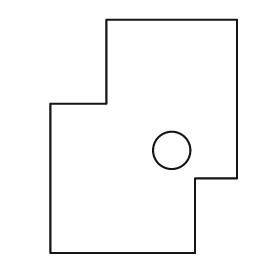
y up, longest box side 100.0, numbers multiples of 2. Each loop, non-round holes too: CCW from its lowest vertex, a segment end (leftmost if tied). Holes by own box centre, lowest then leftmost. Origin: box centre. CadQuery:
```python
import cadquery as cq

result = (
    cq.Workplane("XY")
    .moveTo(-40.0, -50.0)
    .lineTo(22.0, -50.0)
    .lineTo(22.0, -18.0)
    .lineTo(40.0, -18.0)
    .lineTo(40.0, 50.0)
    .lineTo(-16.0, 50.0)
    .lineTo(-16.0, 14.0)
    .lineTo(-40.0, 14.0)
    .close()
    .moveTo(12.0, -6.0)
    .circle(8.0)
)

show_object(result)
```